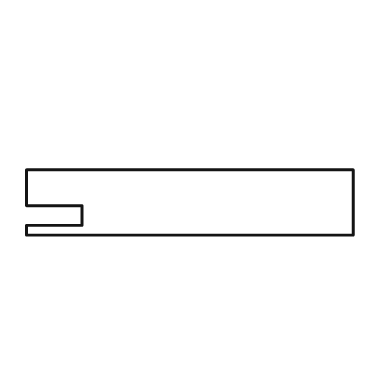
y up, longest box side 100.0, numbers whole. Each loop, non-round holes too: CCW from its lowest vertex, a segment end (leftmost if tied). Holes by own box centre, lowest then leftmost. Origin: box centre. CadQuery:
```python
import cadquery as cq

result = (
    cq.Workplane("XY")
    .moveTo(-50.0, -10.0)
    .lineTo(50.0, -10.0)
    .lineTo(50.0, 10.0)
    .lineTo(-50.0, 10.0)
    .lineTo(-50.0, -1.0)
    .lineTo(-33.0, -1.0)
    .lineTo(-33.0, -7.0)
    .lineTo(-50.0, -7.0)
    .close()
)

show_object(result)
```